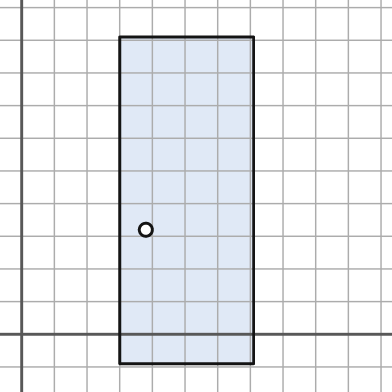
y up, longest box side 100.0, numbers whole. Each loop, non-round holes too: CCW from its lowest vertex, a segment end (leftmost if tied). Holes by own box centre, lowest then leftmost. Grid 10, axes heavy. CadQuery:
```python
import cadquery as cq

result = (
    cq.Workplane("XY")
    .moveTo(30.0, -9.0)
    .lineTo(71.0, -9.0)
    .lineTo(71.0, 91.0)
    .lineTo(30.0, 91.0)
    .close()
    .moveTo(38.0, 32.0)
    .circle(2.0)
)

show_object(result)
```